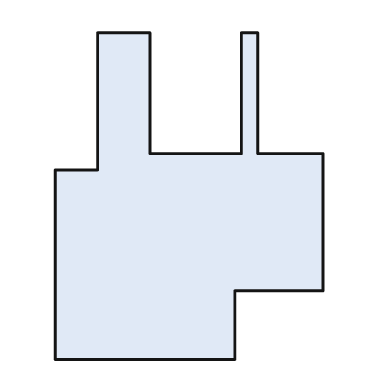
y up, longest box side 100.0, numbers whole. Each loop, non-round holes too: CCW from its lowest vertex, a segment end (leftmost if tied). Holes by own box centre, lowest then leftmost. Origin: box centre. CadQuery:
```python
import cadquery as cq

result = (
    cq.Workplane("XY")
    .moveTo(-41.0, -50.0)
    .lineTo(14.0, -50.0)
    .lineTo(14.0, -29.0)
    .lineTo(41.0, -29.0)
    .lineTo(41.0, 13.0)
    .lineTo(21.0, 13.0)
    .lineTo(21.0, 50.0)
    .lineTo(16.0, 50.0)
    .lineTo(16.0, 13.0)
    .lineTo(-12.0, 13.0)
    .lineTo(-12.0, 50.0)
    .lineTo(-28.0, 50.0)
    .lineTo(-28.0, 8.0)
    .lineTo(-41.0, 8.0)
    .close()
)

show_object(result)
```